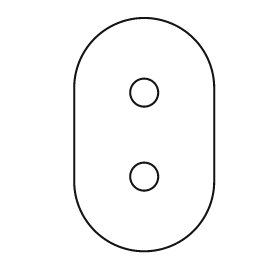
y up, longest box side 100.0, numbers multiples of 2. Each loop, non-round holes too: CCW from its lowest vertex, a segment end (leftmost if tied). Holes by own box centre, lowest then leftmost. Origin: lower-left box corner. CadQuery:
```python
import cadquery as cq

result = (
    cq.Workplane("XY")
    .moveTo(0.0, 30.0)
    .threePointArc((30.0, 0.0), (60.0, 30.0))
    .lineTo(60.0, 70.0)
    .threePointArc((30.0, 100.0), (0.0, 70.0))
    .close()
    .moveTo(30.0, 32.0)
    .circle(6.0)
    .moveTo(30.0, 68.0)
    .circle(6.0)
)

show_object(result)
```